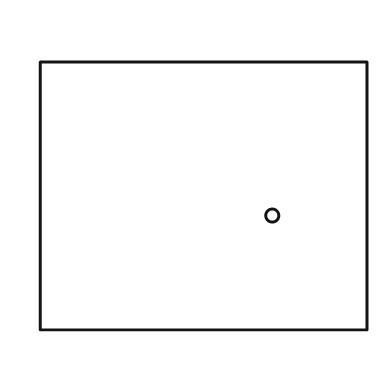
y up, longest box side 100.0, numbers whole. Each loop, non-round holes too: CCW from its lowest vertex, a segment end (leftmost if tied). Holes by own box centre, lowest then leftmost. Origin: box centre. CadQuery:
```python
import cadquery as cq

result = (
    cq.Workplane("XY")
    .moveTo(-50.0, -41.0)
    .lineTo(50.0, -41.0)
    .lineTo(50.0, 41.0)
    .lineTo(-50.0, 41.0)
    .close()
    .moveTo(21.0, -6.0)
    .circle(2.0)
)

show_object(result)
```